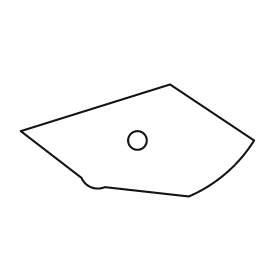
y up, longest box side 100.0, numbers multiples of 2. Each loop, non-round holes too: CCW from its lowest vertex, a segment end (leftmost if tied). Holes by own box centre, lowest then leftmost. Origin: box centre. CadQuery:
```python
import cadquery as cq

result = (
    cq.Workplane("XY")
    .moveTo(22.0, -24.0)
    .threePointArc((38.0, -14.0), (50.0, 0.0))
    .lineTo(14.0, 24.0)
    .lineTo(-50.0, 4.0)
    .lineTo(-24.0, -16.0)
    .threePointArc((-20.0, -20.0), (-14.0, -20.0))
    .close()
    .moveTo(0.0, 0.0)
    .circle(4.0)
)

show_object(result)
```